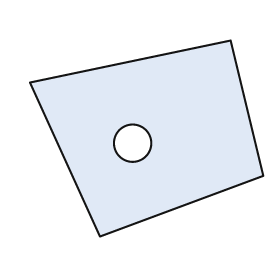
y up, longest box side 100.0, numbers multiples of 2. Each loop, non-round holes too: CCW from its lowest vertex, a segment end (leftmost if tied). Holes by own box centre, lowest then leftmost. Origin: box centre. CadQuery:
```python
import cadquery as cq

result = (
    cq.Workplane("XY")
    .moveTo(-20.0, -42.0)
    .lineTo(50.0, -16.0)
    .lineTo(36.0, 42.0)
    .lineTo(-50.0, 24.0)
    .close()
    .moveTo(-6.0, -2.0)
    .circle(8.0)
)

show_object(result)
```